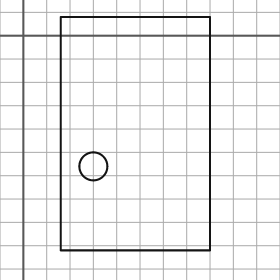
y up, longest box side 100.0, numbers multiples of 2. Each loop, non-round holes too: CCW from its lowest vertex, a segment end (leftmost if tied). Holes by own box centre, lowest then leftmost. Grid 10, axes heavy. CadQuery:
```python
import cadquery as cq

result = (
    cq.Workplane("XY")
    .moveTo(16.0, -92.0)
    .lineTo(80.0, -92.0)
    .lineTo(80.0, 8.0)
    .lineTo(16.0, 8.0)
    .close()
    .moveTo(30.0, -56.0)
    .circle(6.0)
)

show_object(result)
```